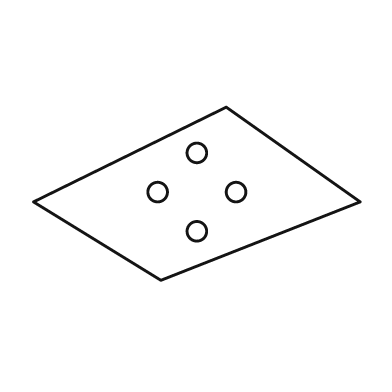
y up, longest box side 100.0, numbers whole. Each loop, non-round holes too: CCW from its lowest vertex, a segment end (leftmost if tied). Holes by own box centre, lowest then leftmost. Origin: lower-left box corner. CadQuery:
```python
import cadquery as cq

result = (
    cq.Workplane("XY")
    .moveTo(39.0, 0.0)
    .lineTo(100.0, 24.0)
    .lineTo(59.0, 53.0)
    .lineTo(0.0, 24.0)
    .close()
    .moveTo(50.0, 15.0)
    .circle(3.0)
    .moveTo(38.0, 27.0)
    .circle(3.0)
    .moveTo(62.0, 27.0)
    .circle(3.0)
    .moveTo(50.0, 39.0)
    .circle(3.0)
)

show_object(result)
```